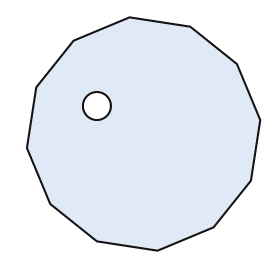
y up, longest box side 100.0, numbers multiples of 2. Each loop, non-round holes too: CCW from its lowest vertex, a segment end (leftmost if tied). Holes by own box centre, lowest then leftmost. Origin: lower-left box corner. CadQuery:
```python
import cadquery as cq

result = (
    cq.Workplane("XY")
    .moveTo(56.0, 0.0)
    .lineTo(80.0, 10.0)
    .lineTo(96.0, 30.0)
    .lineTo(100.0, 56.0)
    .lineTo(90.0, 80.0)
    .lineTo(70.0, 96.0)
    .lineTo(44.0, 100.0)
    .lineTo(20.0, 90.0)
    .lineTo(4.0, 70.0)
    .lineTo(0.0, 44.0)
    .lineTo(10.0, 20.0)
    .lineTo(30.0, 4.0)
    .close()
    .moveTo(30.0, 62.0)
    .circle(6.0)
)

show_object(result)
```